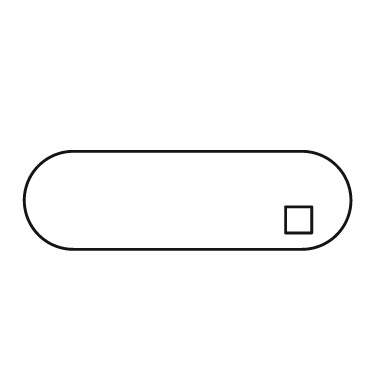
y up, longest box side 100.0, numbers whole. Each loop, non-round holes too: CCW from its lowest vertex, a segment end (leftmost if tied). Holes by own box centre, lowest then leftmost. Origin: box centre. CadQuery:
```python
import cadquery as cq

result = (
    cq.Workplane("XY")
    .moveTo(-35.0, -15.0)
    .lineTo(35.0, -15.0)
    .threePointArc((50.0, 0.0), (35.0, 15.0))
    .lineTo(-35.0, 15.0)
    .threePointArc((-50.0, 0.0), (-35.0, -15.0))
    .close()
    .moveTo(30.0, -10.0)
    .lineTo(38.0, -10.0)
    .lineTo(38.0, -2.0)
    .lineTo(30.0, -2.0)
    .close()
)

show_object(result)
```